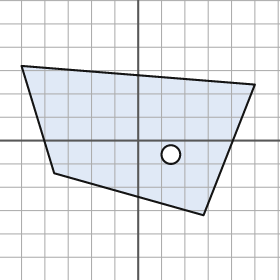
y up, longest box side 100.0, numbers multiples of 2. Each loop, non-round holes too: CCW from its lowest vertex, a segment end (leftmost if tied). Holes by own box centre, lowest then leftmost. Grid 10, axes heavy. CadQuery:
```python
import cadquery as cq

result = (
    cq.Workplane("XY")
    .moveTo(28.0, -32.0)
    .lineTo(50.0, 24.0)
    .lineTo(-50.0, 32.0)
    .lineTo(-36.0, -14.0)
    .close()
    .moveTo(14.0, -6.0)
    .circle(4.0)
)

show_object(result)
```